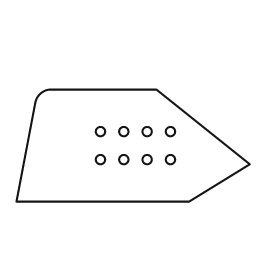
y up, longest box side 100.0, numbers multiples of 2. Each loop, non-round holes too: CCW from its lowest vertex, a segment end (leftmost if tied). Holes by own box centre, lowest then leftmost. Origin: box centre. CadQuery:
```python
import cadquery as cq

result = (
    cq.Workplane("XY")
    .moveTo(-50.0, -24.0)
    .lineTo(24.0, -24.0)
    .lineTo(50.0, -8.0)
    .lineTo(10.0, 24.0)
    .lineTo(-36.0, 24.0)
    .threePointArc((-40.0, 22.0), (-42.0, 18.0))
    .close()
    .moveTo(-14.0, -6.0)
    .circle(2.0)
    .moveTo(-4.0, -6.0)
    .circle(2.0)
    .moveTo(6.0, -6.0)
    .circle(2.0)
    .moveTo(16.0, -6.0)
    .circle(2.0)
    .moveTo(-14.0, 6.0)
    .circle(2.0)
    .moveTo(-4.0, 6.0)
    .circle(2.0)
    .moveTo(6.0, 6.0)
    .circle(2.0)
    .moveTo(16.0, 6.0)
    .circle(2.0)
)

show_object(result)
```